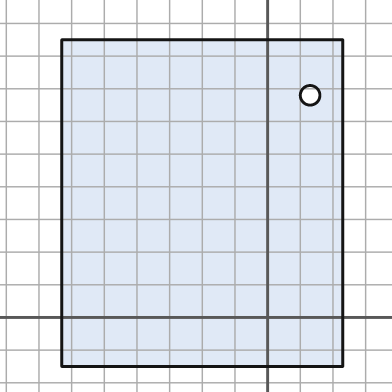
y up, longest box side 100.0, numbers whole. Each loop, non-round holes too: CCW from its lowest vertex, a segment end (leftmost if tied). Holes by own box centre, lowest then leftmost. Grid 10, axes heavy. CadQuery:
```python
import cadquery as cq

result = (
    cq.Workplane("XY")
    .moveTo(-63.0, -15.0)
    .lineTo(23.0, -15.0)
    .lineTo(23.0, 85.0)
    .lineTo(-63.0, 85.0)
    .close()
    .moveTo(13.0, 68.0)
    .circle(3.0)
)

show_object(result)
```